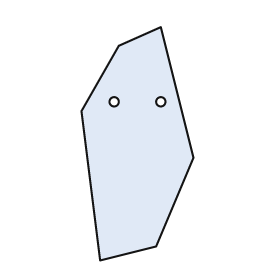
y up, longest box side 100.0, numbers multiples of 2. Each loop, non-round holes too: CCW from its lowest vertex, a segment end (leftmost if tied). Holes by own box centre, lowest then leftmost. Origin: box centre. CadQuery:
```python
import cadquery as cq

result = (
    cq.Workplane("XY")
    .moveTo(-16.0, -50.0)
    .lineTo(8.0, -44.0)
    .lineTo(24.0, -6.0)
    .lineTo(10.0, 50.0)
    .lineTo(-8.0, 42.0)
    .lineTo(-24.0, 14.0)
    .close()
    .moveTo(-10.0, 18.0)
    .circle(2.0)
    .moveTo(10.0, 18.0)
    .circle(2.0)
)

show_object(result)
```